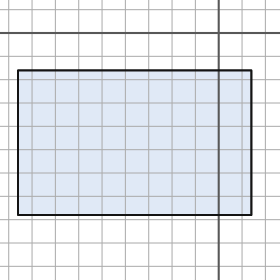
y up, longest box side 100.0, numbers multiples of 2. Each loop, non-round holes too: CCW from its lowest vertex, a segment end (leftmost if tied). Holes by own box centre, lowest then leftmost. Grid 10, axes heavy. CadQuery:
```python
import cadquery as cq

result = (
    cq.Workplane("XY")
    .moveTo(-86.0, -78.0)
    .lineTo(14.0, -78.0)
    .lineTo(14.0, -16.0)
    .lineTo(-86.0, -16.0)
    .close()
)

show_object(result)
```